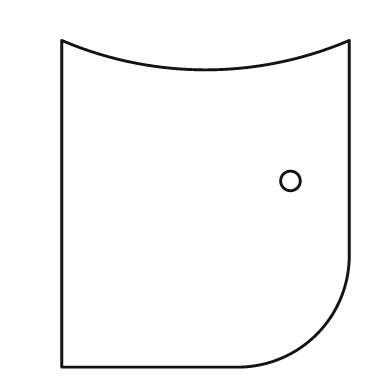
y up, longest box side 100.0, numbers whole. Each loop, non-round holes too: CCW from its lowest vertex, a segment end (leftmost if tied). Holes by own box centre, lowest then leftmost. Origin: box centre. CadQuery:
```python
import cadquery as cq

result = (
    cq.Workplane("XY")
    .moveTo(-44.0, -50.0)
    .lineTo(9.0, -50.0)
    .threePointArc((34.0, -40.0), (44.0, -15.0))
    .lineTo(44.0, 50.0)
    .threePointArc((0.0, 41.0), (-44.0, 50.0))
    .close()
    .moveTo(26.0, 7.0)
    .circle(3.0)
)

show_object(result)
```